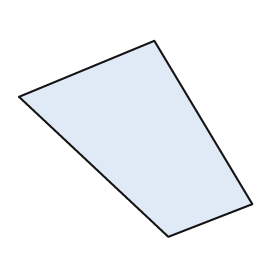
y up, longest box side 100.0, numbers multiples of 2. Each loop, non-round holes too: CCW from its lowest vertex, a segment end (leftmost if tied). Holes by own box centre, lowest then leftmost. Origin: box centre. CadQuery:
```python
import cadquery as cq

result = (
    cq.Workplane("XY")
    .moveTo(14.0, -42.0)
    .lineTo(50.0, -28.0)
    .lineTo(8.0, 42.0)
    .lineTo(-50.0, 18.0)
    .close()
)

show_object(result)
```